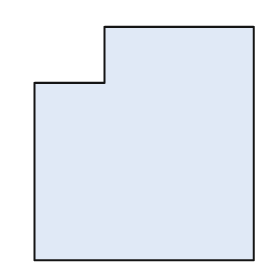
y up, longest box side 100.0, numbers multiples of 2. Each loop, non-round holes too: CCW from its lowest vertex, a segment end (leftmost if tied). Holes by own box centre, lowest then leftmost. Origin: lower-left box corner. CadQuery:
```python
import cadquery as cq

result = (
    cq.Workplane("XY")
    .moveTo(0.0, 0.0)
    .lineTo(94.0, 0.0)
    .lineTo(94.0, 100.0)
    .lineTo(30.0, 100.0)
    .lineTo(30.0, 76.0)
    .lineTo(0.0, 76.0)
    .close()
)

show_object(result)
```